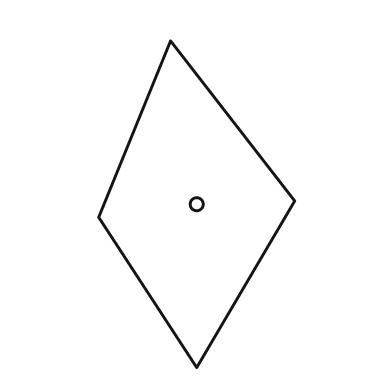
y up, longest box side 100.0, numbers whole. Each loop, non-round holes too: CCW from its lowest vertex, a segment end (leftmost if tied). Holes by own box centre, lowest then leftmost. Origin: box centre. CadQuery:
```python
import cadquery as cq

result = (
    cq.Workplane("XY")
    .moveTo(0.0, -50.0)
    .lineTo(30.0, 1.0)
    .lineTo(-8.0, 50.0)
    .lineTo(-30.0, -4.0)
    .close()
    .moveTo(0.0, 0.0)
    .circle(2.0)
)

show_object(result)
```